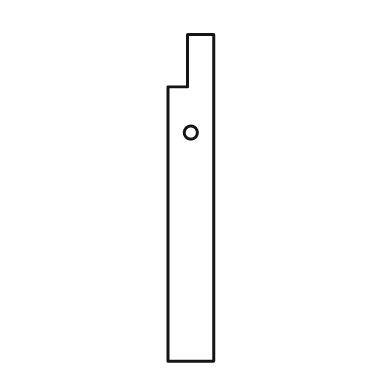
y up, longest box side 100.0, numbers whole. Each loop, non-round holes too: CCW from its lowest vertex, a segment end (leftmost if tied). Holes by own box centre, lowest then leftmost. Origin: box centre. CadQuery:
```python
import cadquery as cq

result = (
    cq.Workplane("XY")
    .moveTo(-7.0, -50.0)
    .lineTo(7.0, -50.0)
    .lineTo(7.0, 50.0)
    .lineTo(-1.0, 50.0)
    .lineTo(-1.0, 34.0)
    .lineTo(-7.0, 34.0)
    .close()
    .moveTo(0.0, 20.0)
    .circle(2.0)
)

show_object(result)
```